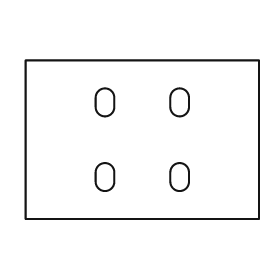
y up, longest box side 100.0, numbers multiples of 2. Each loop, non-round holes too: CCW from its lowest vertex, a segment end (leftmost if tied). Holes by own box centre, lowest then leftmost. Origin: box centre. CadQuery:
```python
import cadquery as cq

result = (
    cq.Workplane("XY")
    .moveTo(-50.0, -34.0)
    .lineTo(50.0, -34.0)
    .lineTo(50.0, 34.0)
    .lineTo(-50.0, 34.0)
    .close()
    .moveTo(-20.0, -18.0)
    .threePointArc((-16.0, -22.0), (-12.0, -18.0))
    .lineTo(-12.0, -14.0)
    .threePointArc((-16.0, -10.0), (-20.0, -14.0))
    .close()
    .moveTo(12.0, -18.0)
    .threePointArc((16.0, -22.0), (20.0, -18.0))
    .lineTo(20.0, -14.0)
    .threePointArc((16.0, -10.0), (12.0, -14.0))
    .close()
    .moveTo(-20.0, 14.0)
    .threePointArc((-16.0, 10.0), (-12.0, 14.0))
    .lineTo(-12.0, 18.0)
    .threePointArc((-16.0, 22.0), (-20.0, 18.0))
    .close()
    .moveTo(12.0, 14.0)
    .threePointArc((16.0, 10.0), (20.0, 14.0))
    .lineTo(20.0, 18.0)
    .threePointArc((16.0, 22.0), (12.0, 18.0))
    .close()
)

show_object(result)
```